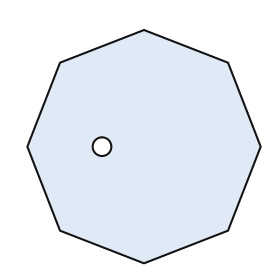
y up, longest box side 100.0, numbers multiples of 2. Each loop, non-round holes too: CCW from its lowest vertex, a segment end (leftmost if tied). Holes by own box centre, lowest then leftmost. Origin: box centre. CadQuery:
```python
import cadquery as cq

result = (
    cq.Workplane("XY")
    .moveTo(0.0, -50.0)
    .lineTo(36.0, -36.0)
    .lineTo(50.0, 0.0)
    .lineTo(36.0, 36.0)
    .lineTo(0.0, 50.0)
    .lineTo(-36.0, 36.0)
    .lineTo(-50.0, 0.0)
    .lineTo(-36.0, -36.0)
    .close()
    .moveTo(-18.0, 0.0)
    .circle(4.0)
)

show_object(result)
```